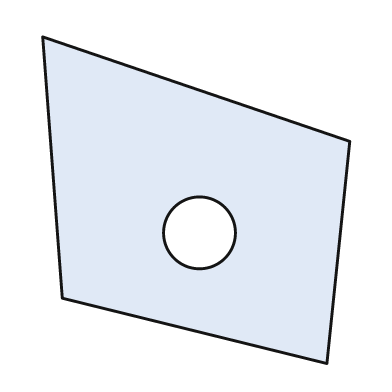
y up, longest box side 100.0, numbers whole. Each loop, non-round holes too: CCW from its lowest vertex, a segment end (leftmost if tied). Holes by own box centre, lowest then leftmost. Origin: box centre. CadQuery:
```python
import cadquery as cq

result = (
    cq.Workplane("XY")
    .moveTo(40.0, -50.0)
    .lineTo(47.0, 18.0)
    .lineTo(-47.0, 50.0)
    .lineTo(-41.0, -30.0)
    .close()
    .moveTo(1.0, -10.0)
    .circle(11.0)
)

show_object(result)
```